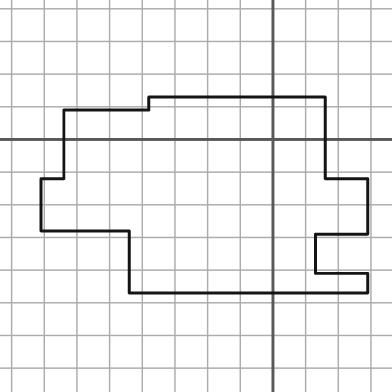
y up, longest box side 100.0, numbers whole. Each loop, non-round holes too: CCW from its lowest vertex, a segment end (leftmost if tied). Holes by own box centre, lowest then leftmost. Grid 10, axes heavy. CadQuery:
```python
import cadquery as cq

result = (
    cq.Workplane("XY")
    .moveTo(-44.0, -47.0)
    .lineTo(29.0, -47.0)
    .lineTo(29.0, -41.0)
    .lineTo(13.0, -41.0)
    .lineTo(13.0, -29.0)
    .lineTo(29.0, -29.0)
    .lineTo(29.0, -12.0)
    .lineTo(16.0, -12.0)
    .lineTo(16.0, 13.0)
    .lineTo(-38.0, 13.0)
    .lineTo(-38.0, 9.0)
    .lineTo(-64.0, 9.0)
    .lineTo(-64.0, -12.0)
    .lineTo(-71.0, -12.0)
    .lineTo(-71.0, -28.0)
    .lineTo(-44.0, -28.0)
    .close()
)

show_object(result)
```